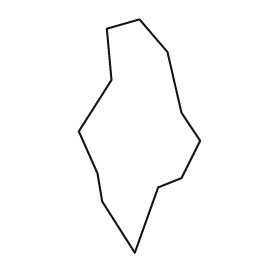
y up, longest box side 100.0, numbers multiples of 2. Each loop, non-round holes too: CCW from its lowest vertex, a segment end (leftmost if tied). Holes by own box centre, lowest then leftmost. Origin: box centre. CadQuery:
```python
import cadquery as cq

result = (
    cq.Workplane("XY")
    .moveTo(-2.0, -50.0)
    .lineTo(8.0, -22.0)
    .lineTo(18.0, -18.0)
    .lineTo(26.0, -2.0)
    .lineTo(18.0, 10.0)
    .lineTo(12.0, 36.0)
    .lineTo(0.0, 50.0)
    .lineTo(-14.0, 46.0)
    .lineTo(-12.0, 24.0)
    .lineTo(-26.0, 2.0)
    .lineTo(-18.0, -16.0)
    .lineTo(-16.0, -28.0)
    .close()
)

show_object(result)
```